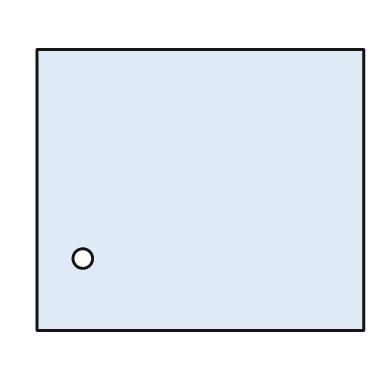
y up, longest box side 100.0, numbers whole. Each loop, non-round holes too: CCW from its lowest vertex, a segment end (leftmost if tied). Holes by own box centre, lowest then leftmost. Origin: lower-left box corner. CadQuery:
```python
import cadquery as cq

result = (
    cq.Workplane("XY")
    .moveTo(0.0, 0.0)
    .lineTo(100.0, 0.0)
    .lineTo(100.0, 86.0)
    .lineTo(0.0, 86.0)
    .close()
    .moveTo(14.0, 22.0)
    .circle(3.0)
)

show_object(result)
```